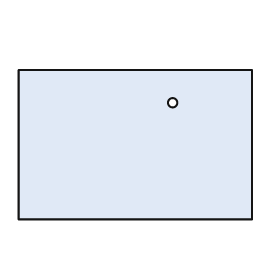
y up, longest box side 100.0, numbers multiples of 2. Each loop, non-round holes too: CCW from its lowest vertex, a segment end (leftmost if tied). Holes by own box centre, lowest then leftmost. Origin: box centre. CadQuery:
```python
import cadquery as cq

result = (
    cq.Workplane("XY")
    .moveTo(-50.0, -32.0)
    .lineTo(50.0, -32.0)
    .lineTo(50.0, 32.0)
    .lineTo(-50.0, 32.0)
    .close()
    .moveTo(16.0, 18.0)
    .circle(2.0)
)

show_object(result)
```